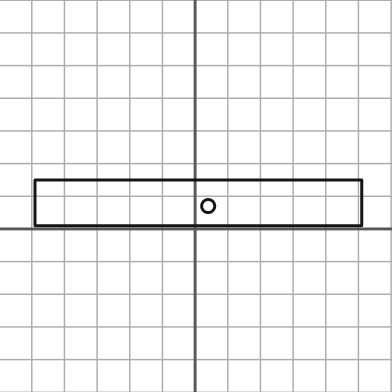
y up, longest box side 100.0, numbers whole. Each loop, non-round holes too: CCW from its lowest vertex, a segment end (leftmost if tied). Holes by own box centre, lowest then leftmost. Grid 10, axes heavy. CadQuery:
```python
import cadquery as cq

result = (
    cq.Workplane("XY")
    .moveTo(-49.0, 1.0)
    .lineTo(51.0, 1.0)
    .lineTo(51.0, 15.0)
    .lineTo(-49.0, 15.0)
    .close()
    .moveTo(4.0, 7.0)
    .circle(2.0)
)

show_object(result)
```